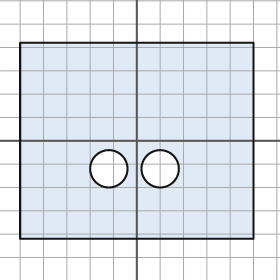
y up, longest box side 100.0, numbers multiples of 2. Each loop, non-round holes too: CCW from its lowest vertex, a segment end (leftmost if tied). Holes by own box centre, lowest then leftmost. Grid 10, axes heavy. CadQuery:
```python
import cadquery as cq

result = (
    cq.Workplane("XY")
    .moveTo(-50.0, -42.0)
    .lineTo(50.0, -42.0)
    .lineTo(50.0, 42.0)
    .lineTo(-50.0, 42.0)
    .close()
    .moveTo(-12.0, -12.0)
    .circle(8.0)
    .moveTo(10.0, -12.0)
    .circle(8.0)
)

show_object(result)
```